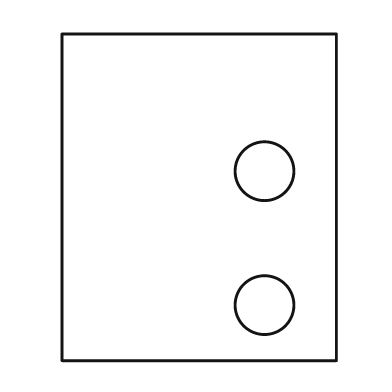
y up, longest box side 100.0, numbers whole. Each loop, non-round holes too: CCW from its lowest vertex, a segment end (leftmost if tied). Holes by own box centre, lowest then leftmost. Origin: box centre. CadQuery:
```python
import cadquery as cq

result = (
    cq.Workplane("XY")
    .moveTo(-42.0, -50.0)
    .lineTo(42.0, -50.0)
    .lineTo(42.0, 50.0)
    .lineTo(-42.0, 50.0)
    .close()
    .moveTo(20.0, -33.0)
    .circle(9.0)
    .moveTo(20.0, 8.0)
    .circle(9.0)
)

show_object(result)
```